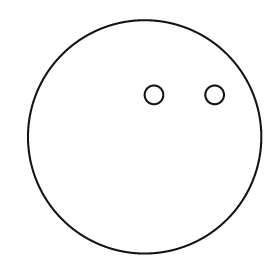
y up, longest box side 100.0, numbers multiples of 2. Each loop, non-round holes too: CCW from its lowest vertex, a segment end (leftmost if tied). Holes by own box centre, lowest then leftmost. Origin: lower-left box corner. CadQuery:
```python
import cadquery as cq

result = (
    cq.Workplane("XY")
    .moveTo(50.0, 50.0)
    .circle(50.0)
    .moveTo(54.0, 68.0)
    .circle(4.0)
    .moveTo(80.0, 68.0)
    .circle(4.0)
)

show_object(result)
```